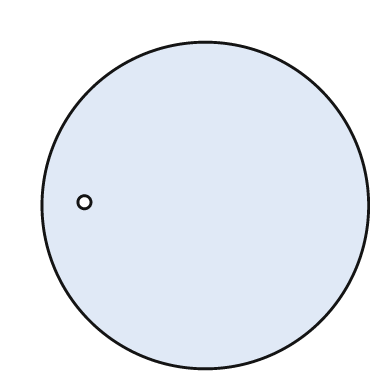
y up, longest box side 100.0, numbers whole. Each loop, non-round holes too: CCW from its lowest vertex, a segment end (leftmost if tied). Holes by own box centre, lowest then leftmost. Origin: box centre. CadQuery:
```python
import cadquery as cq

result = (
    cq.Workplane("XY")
    .moveTo(0.0, 0.0)
    .circle(50.0)
    .moveTo(-37.0, 1.0)
    .circle(2.0)
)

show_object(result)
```